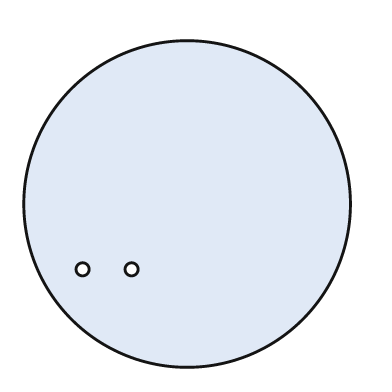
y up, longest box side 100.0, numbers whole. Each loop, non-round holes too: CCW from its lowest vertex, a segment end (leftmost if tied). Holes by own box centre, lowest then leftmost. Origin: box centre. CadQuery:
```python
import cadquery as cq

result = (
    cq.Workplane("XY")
    .moveTo(0.0, 0.0)
    .circle(50.0)
    .moveTo(-32.0, -20.0)
    .circle(2.0)
    .moveTo(-17.0, -20.0)
    .circle(2.0)
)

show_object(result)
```